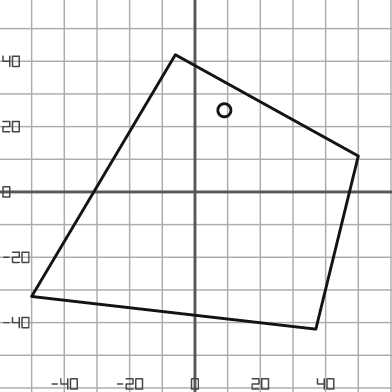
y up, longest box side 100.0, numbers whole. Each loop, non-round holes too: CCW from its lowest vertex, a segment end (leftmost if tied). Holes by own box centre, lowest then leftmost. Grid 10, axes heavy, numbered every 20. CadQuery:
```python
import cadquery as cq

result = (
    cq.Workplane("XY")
    .moveTo(37.0, -42.0)
    .lineTo(50.0, 11.0)
    .lineTo(-6.0, 42.0)
    .lineTo(-50.0, -32.0)
    .close()
    .moveTo(9.0, 25.0)
    .circle(2.0)
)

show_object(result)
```